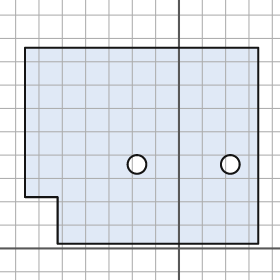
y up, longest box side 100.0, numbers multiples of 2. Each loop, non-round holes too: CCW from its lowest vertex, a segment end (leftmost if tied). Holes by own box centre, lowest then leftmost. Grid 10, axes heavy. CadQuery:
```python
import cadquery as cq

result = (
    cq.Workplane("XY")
    .moveTo(-52.0, 2.0)
    .lineTo(34.0, 2.0)
    .lineTo(34.0, 86.0)
    .lineTo(-66.0, 86.0)
    .lineTo(-66.0, 22.0)
    .lineTo(-52.0, 22.0)
    .close()
    .moveTo(-18.0, 36.0)
    .circle(4.0)
    .moveTo(22.0, 36.0)
    .circle(4.0)
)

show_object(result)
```